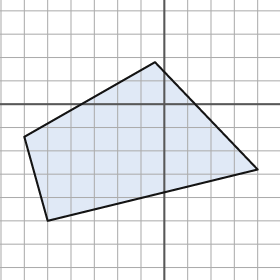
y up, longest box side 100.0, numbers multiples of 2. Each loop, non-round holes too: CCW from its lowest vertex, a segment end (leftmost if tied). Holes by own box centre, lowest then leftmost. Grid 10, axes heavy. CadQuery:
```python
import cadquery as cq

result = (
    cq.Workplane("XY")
    .moveTo(-50.0, -50.0)
    .lineTo(40.0, -28.0)
    .lineTo(-4.0, 18.0)
    .lineTo(-60.0, -14.0)
    .close()
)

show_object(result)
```